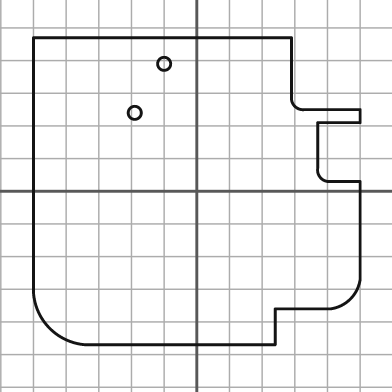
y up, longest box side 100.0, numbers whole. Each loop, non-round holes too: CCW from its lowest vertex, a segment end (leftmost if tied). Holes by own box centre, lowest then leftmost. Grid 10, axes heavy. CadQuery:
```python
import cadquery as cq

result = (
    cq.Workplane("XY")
    .moveTo(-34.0, -47.0)
    .lineTo(24.0, -47.0)
    .lineTo(24.0, -36.0)
    .lineTo(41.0, -36.0)
    .threePointArc((47.0, -33.0), (50.0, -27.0))
    .lineTo(50.0, 3.0)
    .lineTo(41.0, 3.0)
    .threePointArc((38.0, 4.0), (37.0, 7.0))
    .lineTo(37.0, 21.0)
    .lineTo(50.0, 21.0)
    .lineTo(50.0, 25.0)
    .lineTo(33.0, 25.0)
    .threePointArc((30.0, 26.0), (29.0, 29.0))
    .lineTo(29.0, 47.0)
    .lineTo(-50.0, 47.0)
    .lineTo(-50.0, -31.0)
    .threePointArc((-45.0, -42.0), (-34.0, -47.0))
    .close()
    .moveTo(-19.0, 24.0)
    .circle(2.0)
    .moveTo(-10.0, 39.0)
    .circle(2.0)
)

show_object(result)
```